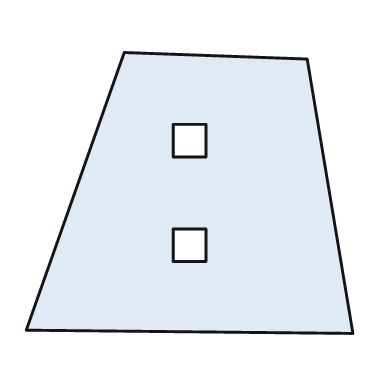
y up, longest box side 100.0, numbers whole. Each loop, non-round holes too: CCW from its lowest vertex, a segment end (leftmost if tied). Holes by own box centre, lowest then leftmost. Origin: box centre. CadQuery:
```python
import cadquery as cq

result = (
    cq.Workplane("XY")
    .moveTo(50.0, -43.0)
    .lineTo(36.0, 41.0)
    .lineTo(-20.0, 43.0)
    .lineTo(-50.0, -42.0)
    .close()
    .moveTo(-5.0, -21.0)
    .lineTo(5.0, -21.0)
    .lineTo(5.0, -11.0)
    .lineTo(-5.0, -11.0)
    .close()
    .moveTo(-5.0, 11.0)
    .lineTo(5.0, 11.0)
    .lineTo(5.0, 21.0)
    .lineTo(-5.0, 21.0)
    .close()
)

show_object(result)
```